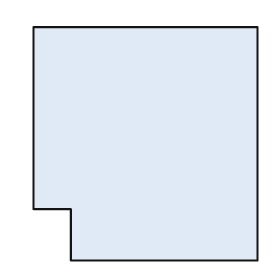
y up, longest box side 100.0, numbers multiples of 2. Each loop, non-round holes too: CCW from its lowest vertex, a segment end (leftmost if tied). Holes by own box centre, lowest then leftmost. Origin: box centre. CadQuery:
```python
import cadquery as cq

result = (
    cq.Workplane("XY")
    .moveTo(-32.0, -50.0)
    .lineTo(48.0, -50.0)
    .lineTo(48.0, 50.0)
    .lineTo(-48.0, 50.0)
    .lineTo(-48.0, -28.0)
    .lineTo(-32.0, -28.0)
    .close()
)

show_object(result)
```